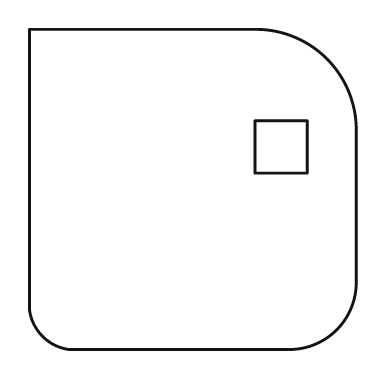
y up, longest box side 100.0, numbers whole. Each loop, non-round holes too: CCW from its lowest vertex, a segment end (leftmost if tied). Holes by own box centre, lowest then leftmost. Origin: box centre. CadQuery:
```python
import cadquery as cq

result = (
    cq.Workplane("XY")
    .moveTo(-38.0, -49.0)
    .lineTo(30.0, -49.0)
    .threePointArc((44.0, -43.0), (50.0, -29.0))
    .lineTo(50.0, 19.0)
    .threePointArc((41.0, 40.0), (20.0, 49.0))
    .lineTo(-50.0, 49.0)
    .lineTo(-50.0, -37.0)
    .threePointArc((-46.0, -45.0), (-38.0, -49.0))
    .close()
    .moveTo(19.0, 5.0)
    .lineTo(35.0, 5.0)
    .lineTo(35.0, 21.0)
    .lineTo(19.0, 21.0)
    .close()
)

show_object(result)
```